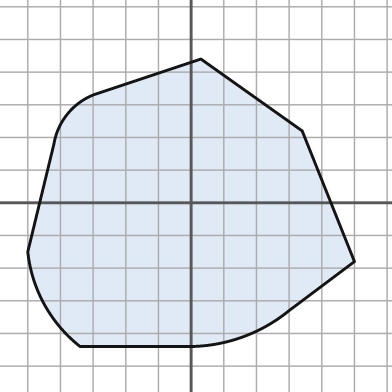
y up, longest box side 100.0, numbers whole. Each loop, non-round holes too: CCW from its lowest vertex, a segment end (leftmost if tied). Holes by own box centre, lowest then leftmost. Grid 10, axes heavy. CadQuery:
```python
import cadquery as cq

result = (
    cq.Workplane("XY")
    .moveTo(-34.0, -44.0)
    .lineTo(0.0, -44.0)
    .threePointArc((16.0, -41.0), (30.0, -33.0))
    .lineTo(50.0, -18.0)
    .lineTo(34.0, 22.0)
    .lineTo(3.0, 44.0)
    .lineTo(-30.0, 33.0)
    .threePointArc((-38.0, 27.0), (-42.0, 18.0))
    .lineTo(-50.0, -15.0)
    .threePointArc((-45.0, -31.0), (-34.0, -44.0))
    .close()
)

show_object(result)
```